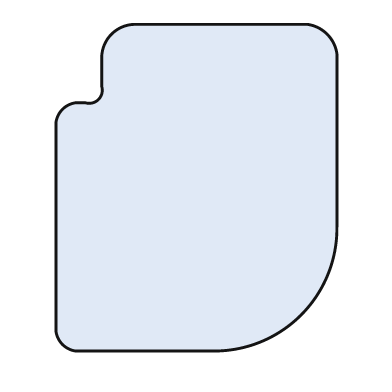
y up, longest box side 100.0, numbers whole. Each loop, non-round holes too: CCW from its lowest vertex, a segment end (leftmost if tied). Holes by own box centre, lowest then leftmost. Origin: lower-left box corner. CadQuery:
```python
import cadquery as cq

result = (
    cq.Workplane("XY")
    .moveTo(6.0, 0.0)
    .lineTo(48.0, 0.0)
    .threePointArc((75.0, 11.0), (86.0, 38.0))
    .lineTo(86.0, 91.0)
    .threePointArc((83.0, 97.0), (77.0, 100.0))
    .lineTo(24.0, 100.0)
    .threePointArc((17.0, 97.0), (14.0, 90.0))
    .lineTo(14.0, 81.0)
    .threePointArc((13.0, 77.0), (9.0, 76.0))
    .lineTo(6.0, 76.0)
    .threePointArc((2.0, 74.0), (0.0, 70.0))
    .lineTo(0.0, 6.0)
    .threePointArc((2.0, 2.0), (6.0, 0.0))
    .close()
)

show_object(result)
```